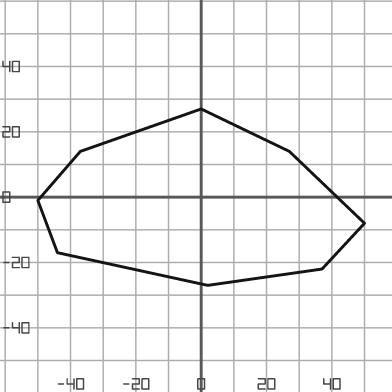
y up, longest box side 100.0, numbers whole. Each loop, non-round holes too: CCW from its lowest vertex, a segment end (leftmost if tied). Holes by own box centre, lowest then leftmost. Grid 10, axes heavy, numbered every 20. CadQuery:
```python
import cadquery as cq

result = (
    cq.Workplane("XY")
    .moveTo(2.0, -27.0)
    .lineTo(37.0, -22.0)
    .lineTo(50.0, -8.0)
    .lineTo(27.0, 14.0)
    .lineTo(0.0, 27.0)
    .lineTo(-37.0, 14.0)
    .lineTo(-50.0, -1.0)
    .lineTo(-44.0, -17.0)
    .close()
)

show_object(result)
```